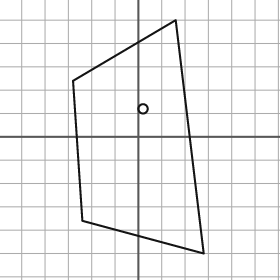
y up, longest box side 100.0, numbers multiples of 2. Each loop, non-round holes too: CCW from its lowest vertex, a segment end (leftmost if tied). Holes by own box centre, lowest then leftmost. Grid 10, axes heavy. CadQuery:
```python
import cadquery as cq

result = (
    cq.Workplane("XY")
    .moveTo(28.0, -50.0)
    .lineTo(16.0, 50.0)
    .lineTo(-28.0, 24.0)
    .lineTo(-24.0, -36.0)
    .close()
    .moveTo(2.0, 12.0)
    .circle(2.0)
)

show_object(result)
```